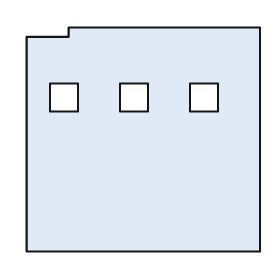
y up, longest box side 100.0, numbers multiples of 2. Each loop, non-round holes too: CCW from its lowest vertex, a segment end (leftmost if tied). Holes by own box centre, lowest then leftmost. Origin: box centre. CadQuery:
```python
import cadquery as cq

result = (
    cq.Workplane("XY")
    .moveTo(-50.0, -48.0)
    .lineTo(50.0, -48.0)
    .lineTo(50.0, 48.0)
    .lineTo(-32.0, 48.0)
    .lineTo(-32.0, 44.0)
    .lineTo(-50.0, 44.0)
    .close()
    .moveTo(-40.0, 12.0)
    .lineTo(-28.0, 12.0)
    .lineTo(-28.0, 24.0)
    .lineTo(-40.0, 24.0)
    .close()
    .moveTo(-10.0, 12.0)
    .lineTo(2.0, 12.0)
    .lineTo(2.0, 24.0)
    .lineTo(-10.0, 24.0)
    .close()
    .moveTo(20.0, 12.0)
    .lineTo(32.0, 12.0)
    .lineTo(32.0, 24.0)
    .lineTo(20.0, 24.0)
    .close()
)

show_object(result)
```